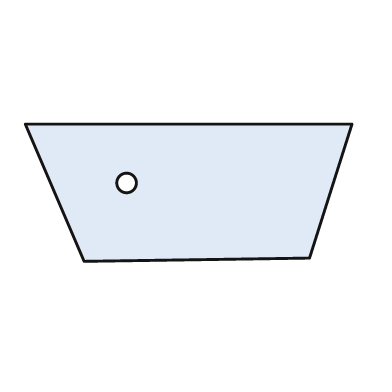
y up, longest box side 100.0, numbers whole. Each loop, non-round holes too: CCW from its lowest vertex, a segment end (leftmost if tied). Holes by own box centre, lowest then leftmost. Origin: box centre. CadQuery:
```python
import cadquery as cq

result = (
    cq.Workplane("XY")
    .moveTo(-32.0, -21.0)
    .lineTo(37.0, -20.0)
    .lineTo(50.0, 21.0)
    .lineTo(-50.0, 21.0)
    .close()
    .moveTo(-19.0, 3.0)
    .circle(3.0)
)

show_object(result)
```